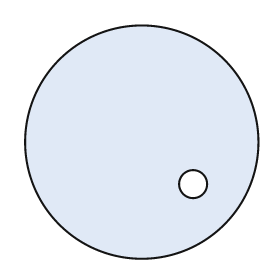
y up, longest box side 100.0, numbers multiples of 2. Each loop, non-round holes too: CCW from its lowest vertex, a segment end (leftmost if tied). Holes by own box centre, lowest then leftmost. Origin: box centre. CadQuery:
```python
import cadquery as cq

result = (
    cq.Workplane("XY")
    .moveTo(0.0, 0.0)
    .circle(50.0)
    .moveTo(22.0, -18.0)
    .circle(6.0)
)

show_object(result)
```